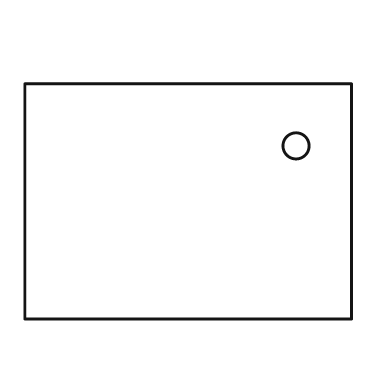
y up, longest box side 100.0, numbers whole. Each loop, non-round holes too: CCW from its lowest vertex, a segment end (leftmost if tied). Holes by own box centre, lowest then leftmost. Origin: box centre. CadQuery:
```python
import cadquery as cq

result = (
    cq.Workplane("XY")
    .moveTo(-50.0, -36.0)
    .lineTo(50.0, -36.0)
    .lineTo(50.0, 36.0)
    .lineTo(-50.0, 36.0)
    .close()
    .moveTo(33.0, 17.0)
    .circle(4.0)
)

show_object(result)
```